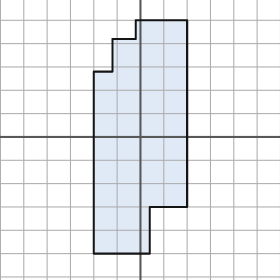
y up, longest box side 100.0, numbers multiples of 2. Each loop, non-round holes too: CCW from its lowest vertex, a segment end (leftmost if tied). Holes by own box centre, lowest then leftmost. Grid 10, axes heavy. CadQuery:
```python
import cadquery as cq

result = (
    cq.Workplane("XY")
    .moveTo(-20.0, -50.0)
    .lineTo(4.0, -50.0)
    .lineTo(4.0, -30.0)
    .lineTo(20.0, -30.0)
    .lineTo(20.0, 50.0)
    .lineTo(-2.0, 50.0)
    .lineTo(-2.0, 42.0)
    .lineTo(-12.0, 42.0)
    .lineTo(-12.0, 28.0)
    .lineTo(-20.0, 28.0)
    .close()
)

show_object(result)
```